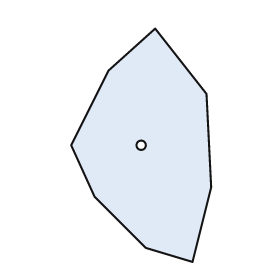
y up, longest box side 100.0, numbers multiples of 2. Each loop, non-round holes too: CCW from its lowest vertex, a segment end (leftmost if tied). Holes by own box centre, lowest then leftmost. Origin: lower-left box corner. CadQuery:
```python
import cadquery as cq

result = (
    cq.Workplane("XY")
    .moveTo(52.0, 0.0)
    .lineTo(60.0, 32.0)
    .lineTo(58.0, 72.0)
    .lineTo(36.0, 100.0)
    .lineTo(16.0, 82.0)
    .lineTo(0.0, 50.0)
    .lineTo(10.0, 28.0)
    .lineTo(32.0, 6.0)
    .close()
    .moveTo(30.0, 50.0)
    .circle(2.0)
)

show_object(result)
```